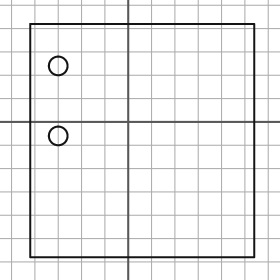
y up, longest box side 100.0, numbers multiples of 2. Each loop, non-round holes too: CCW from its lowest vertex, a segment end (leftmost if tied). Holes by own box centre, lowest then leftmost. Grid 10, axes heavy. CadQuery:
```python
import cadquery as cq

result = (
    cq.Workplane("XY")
    .moveTo(-42.0, -58.0)
    .lineTo(54.0, -58.0)
    .lineTo(54.0, 42.0)
    .lineTo(-42.0, 42.0)
    .close()
    .moveTo(-30.0, -6.0)
    .circle(4.0)
    .moveTo(-30.0, 24.0)
    .circle(4.0)
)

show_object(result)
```